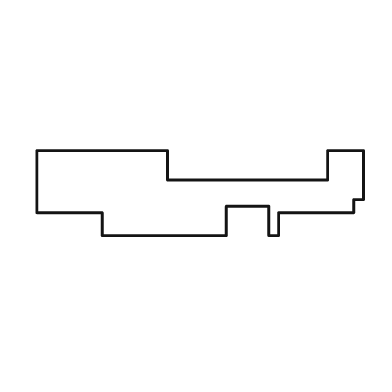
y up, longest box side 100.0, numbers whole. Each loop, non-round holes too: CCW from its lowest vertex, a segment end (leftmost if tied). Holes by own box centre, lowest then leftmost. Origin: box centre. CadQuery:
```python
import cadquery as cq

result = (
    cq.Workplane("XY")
    .moveTo(-30.0, -13.0)
    .lineTo(8.0, -13.0)
    .lineTo(8.0, -4.0)
    .lineTo(21.0, -4.0)
    .lineTo(21.0, -13.0)
    .lineTo(24.0, -13.0)
    .lineTo(24.0, -6.0)
    .lineTo(47.0, -6.0)
    .lineTo(47.0, -2.0)
    .lineTo(50.0, -2.0)
    .lineTo(50.0, 13.0)
    .lineTo(39.0, 13.0)
    .lineTo(39.0, 4.0)
    .lineTo(-10.0, 4.0)
    .lineTo(-10.0, 13.0)
    .lineTo(-50.0, 13.0)
    .lineTo(-50.0, -6.0)
    .lineTo(-30.0, -6.0)
    .close()
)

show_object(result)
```